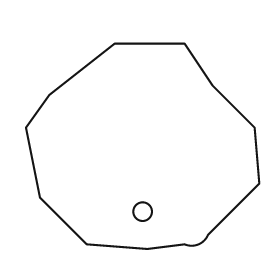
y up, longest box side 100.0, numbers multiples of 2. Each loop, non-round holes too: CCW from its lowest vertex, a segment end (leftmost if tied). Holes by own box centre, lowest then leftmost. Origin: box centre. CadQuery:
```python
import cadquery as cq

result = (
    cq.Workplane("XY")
    .moveTo(2.0, -44.0)
    .lineTo(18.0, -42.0)
    .threePointArc((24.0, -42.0), (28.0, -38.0))
    .lineTo(50.0, -16.0)
    .lineTo(48.0, 8.0)
    .lineTo(30.0, 26.0)
    .lineTo(18.0, 44.0)
    .lineTo(-12.0, 44.0)
    .lineTo(-40.0, 22.0)
    .lineTo(-50.0, 8.0)
    .lineTo(-44.0, -22.0)
    .lineTo(-24.0, -42.0)
    .close()
    .moveTo(0.0, -28.0)
    .circle(4.0)
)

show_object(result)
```